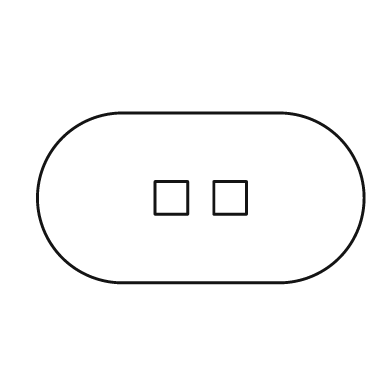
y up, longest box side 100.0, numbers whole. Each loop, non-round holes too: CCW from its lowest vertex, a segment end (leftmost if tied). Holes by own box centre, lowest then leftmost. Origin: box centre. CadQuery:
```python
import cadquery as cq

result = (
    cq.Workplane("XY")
    .moveTo(-24.0, -26.0)
    .lineTo(24.0, -26.0)
    .threePointArc((50.0, 0.0), (24.0, 26.0))
    .lineTo(-24.0, 26.0)
    .threePointArc((-50.0, 0.0), (-24.0, -26.0))
    .close()
    .moveTo(-14.0, -5.0)
    .lineTo(-4.0, -5.0)
    .lineTo(-4.0, 5.0)
    .lineTo(-14.0, 5.0)
    .close()
    .moveTo(4.0, -5.0)
    .lineTo(14.0, -5.0)
    .lineTo(14.0, 5.0)
    .lineTo(4.0, 5.0)
    .close()
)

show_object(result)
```